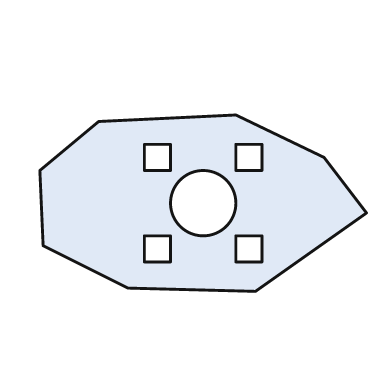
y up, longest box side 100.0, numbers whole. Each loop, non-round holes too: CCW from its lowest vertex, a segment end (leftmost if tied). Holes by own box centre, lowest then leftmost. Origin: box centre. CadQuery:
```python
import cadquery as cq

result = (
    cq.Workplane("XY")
    .moveTo(16.0, -27.0)
    .lineTo(50.0, -3.0)
    .lineTo(37.0, 14.0)
    .lineTo(10.0, 27.0)
    .lineTo(-32.0, 25.0)
    .lineTo(-50.0, 10.0)
    .lineTo(-49.0, -13.0)
    .lineTo(-23.0, -26.0)
    .close()
    .moveTo(-18.0, -18.0)
    .lineTo(-10.0, -18.0)
    .lineTo(-10.0, -10.0)
    .lineTo(-18.0, -10.0)
    .close()
    .moveTo(10.0, -18.0)
    .lineTo(18.0, -18.0)
    .lineTo(18.0, -10.0)
    .lineTo(10.0, -10.0)
    .close()
    .moveTo(0.0, 0.0)
    .circle(10.0)
    .moveTo(-18.0, 10.0)
    .lineTo(-10.0, 10.0)
    .lineTo(-10.0, 18.0)
    .lineTo(-18.0, 18.0)
    .close()
    .moveTo(10.0, 10.0)
    .lineTo(18.0, 10.0)
    .lineTo(18.0, 18.0)
    .lineTo(10.0, 18.0)
    .close()
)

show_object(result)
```